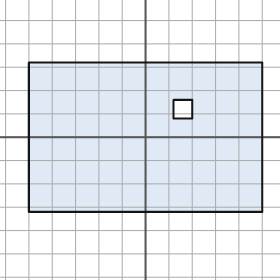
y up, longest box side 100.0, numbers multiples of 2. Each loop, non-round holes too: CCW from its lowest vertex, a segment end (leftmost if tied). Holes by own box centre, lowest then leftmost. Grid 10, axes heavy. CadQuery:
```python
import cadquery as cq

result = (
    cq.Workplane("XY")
    .moveTo(-50.0, -32.0)
    .lineTo(50.0, -32.0)
    .lineTo(50.0, 32.0)
    .lineTo(-50.0, 32.0)
    .close()
    .moveTo(12.0, 8.0)
    .lineTo(20.0, 8.0)
    .lineTo(20.0, 16.0)
    .lineTo(12.0, 16.0)
    .close()
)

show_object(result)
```